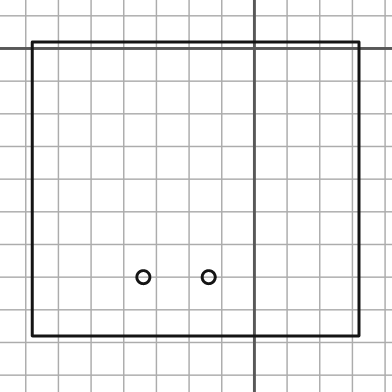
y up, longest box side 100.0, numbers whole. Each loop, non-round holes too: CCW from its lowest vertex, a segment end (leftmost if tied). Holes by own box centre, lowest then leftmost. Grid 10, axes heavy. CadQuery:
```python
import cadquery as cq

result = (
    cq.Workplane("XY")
    .moveTo(-68.0, -88.0)
    .lineTo(32.0, -88.0)
    .lineTo(32.0, 2.0)
    .lineTo(-68.0, 2.0)
    .close()
    .moveTo(-34.0, -70.0)
    .circle(2.0)
    .moveTo(-14.0, -70.0)
    .circle(2.0)
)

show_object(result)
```